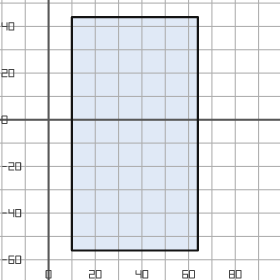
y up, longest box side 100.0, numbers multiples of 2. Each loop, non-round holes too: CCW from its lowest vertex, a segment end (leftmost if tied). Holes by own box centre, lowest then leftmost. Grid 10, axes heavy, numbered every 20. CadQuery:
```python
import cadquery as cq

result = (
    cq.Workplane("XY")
    .moveTo(10.0, -56.0)
    .lineTo(64.0, -56.0)
    .lineTo(64.0, 44.0)
    .lineTo(10.0, 44.0)
    .close()
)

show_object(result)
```